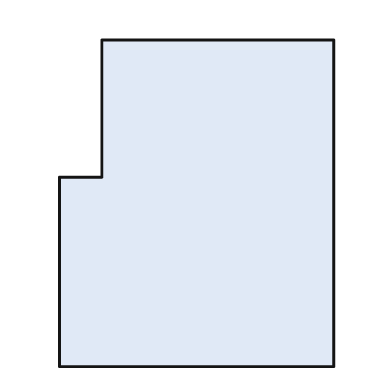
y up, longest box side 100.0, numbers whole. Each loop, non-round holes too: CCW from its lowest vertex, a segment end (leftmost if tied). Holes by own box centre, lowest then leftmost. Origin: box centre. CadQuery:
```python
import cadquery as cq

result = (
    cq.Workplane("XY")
    .moveTo(-42.0, -50.0)
    .lineTo(42.0, -50.0)
    .lineTo(42.0, 50.0)
    .lineTo(-29.0, 50.0)
    .lineTo(-29.0, 8.0)
    .lineTo(-42.0, 8.0)
    .close()
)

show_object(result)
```